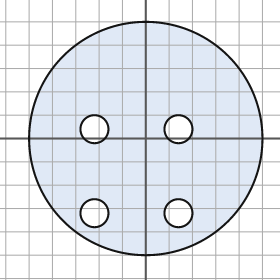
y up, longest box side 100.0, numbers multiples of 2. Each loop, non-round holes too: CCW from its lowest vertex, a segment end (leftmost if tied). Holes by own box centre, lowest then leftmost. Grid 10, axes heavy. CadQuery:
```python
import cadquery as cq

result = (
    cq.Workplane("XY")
    .moveTo(0.0, 0.0)
    .circle(50.0)
    .moveTo(-22.0, -32.0)
    .circle(6.0)
    .moveTo(14.0, -32.0)
    .circle(6.0)
    .moveTo(-22.0, 4.0)
    .circle(6.0)
    .moveTo(14.0, 4.0)
    .circle(6.0)
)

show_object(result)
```